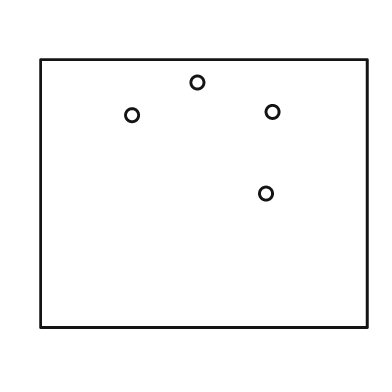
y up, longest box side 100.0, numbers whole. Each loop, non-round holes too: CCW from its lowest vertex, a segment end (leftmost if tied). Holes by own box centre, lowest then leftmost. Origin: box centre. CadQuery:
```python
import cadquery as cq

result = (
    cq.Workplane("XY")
    .moveTo(-50.0, -41.0)
    .lineTo(50.0, -41.0)
    .lineTo(50.0, 41.0)
    .lineTo(-50.0, 41.0)
    .close()
    .moveTo(19.0, 0.0)
    .circle(2.0)
    .moveTo(-22.0, 24.0)
    .circle(2.0)
    .moveTo(21.0, 25.0)
    .circle(2.0)
    .moveTo(-2.0, 34.0)
    .circle(2.0)
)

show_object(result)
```